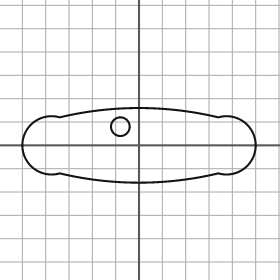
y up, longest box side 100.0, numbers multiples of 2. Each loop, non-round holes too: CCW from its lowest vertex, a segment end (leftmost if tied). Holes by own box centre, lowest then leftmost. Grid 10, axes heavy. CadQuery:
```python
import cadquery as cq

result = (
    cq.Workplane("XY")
    .moveTo(-34.0, -12.0)
    .threePointArc((0.0, -16.0), (34.0, -12.0))
    .threePointArc((50.0, 0.0), (34.0, 12.0))
    .threePointArc((0.0, 16.0), (-34.0, 12.0))
    .threePointArc((-50.0, 0.0), (-34.0, -12.0))
    .close()
    .moveTo(-8.0, 8.0)
    .circle(4.0)
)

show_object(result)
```